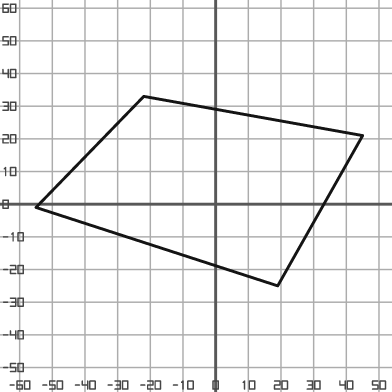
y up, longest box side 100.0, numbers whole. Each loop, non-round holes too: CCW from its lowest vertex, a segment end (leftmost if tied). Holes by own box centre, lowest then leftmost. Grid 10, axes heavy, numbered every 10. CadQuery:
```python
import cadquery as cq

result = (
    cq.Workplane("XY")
    .moveTo(19.0, -25.0)
    .lineTo(45.0, 21.0)
    .lineTo(-22.0, 33.0)
    .lineTo(-55.0, -1.0)
    .close()
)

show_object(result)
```